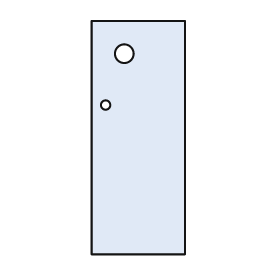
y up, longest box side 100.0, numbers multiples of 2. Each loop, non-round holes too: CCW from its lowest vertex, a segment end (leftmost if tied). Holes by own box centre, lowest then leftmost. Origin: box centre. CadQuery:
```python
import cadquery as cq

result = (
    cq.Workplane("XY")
    .moveTo(-20.0, -50.0)
    .lineTo(20.0, -50.0)
    .lineTo(20.0, 50.0)
    .lineTo(-20.0, 50.0)
    .close()
    .moveTo(-14.0, 14.0)
    .circle(2.0)
    .moveTo(-6.0, 36.0)
    .circle(4.0)
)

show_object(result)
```